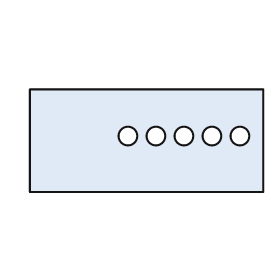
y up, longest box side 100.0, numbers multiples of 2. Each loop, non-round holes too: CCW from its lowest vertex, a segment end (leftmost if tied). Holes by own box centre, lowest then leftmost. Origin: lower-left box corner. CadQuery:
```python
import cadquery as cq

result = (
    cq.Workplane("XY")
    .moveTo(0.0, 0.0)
    .lineTo(100.0, 0.0)
    .lineTo(100.0, 44.0)
    .lineTo(0.0, 44.0)
    .close()
    .moveTo(42.0, 24.0)
    .circle(4.0)
    .moveTo(54.0, 24.0)
    .circle(4.0)
    .moveTo(66.0, 24.0)
    .circle(4.0)
    .moveTo(78.0, 24.0)
    .circle(4.0)
    .moveTo(90.0, 24.0)
    .circle(4.0)
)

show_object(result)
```